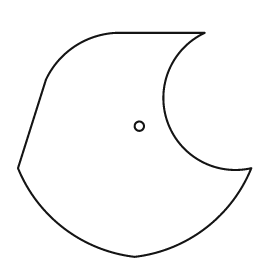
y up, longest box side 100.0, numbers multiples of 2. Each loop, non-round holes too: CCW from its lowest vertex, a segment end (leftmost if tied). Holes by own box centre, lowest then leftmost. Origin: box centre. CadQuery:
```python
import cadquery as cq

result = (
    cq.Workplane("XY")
    .moveTo(0.0, -48.0)
    .threePointArc((30.0, -36.0), (50.0, -10.0))
    .threePointArc((14.0, 10.0), (30.0, 48.0))
    .lineTo(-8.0, 48.0)
    .threePointArc((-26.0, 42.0), (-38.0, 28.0))
    .lineTo(-50.0, -10.0)
    .threePointArc((-30.0, -36.0), (0.0, -48.0))
    .close()
    .moveTo(2.0, 8.0)
    .circle(2.0)
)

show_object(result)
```